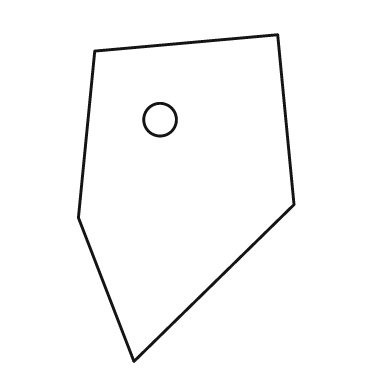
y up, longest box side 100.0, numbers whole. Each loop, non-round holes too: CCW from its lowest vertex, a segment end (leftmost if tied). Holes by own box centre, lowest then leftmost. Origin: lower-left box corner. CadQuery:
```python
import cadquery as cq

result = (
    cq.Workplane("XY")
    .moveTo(17.0, 0.0)
    .lineTo(66.0, 48.0)
    .lineTo(61.0, 100.0)
    .lineTo(5.0, 95.0)
    .lineTo(0.0, 44.0)
    .close()
    .moveTo(25.0, 74.0)
    .circle(5.0)
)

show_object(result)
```